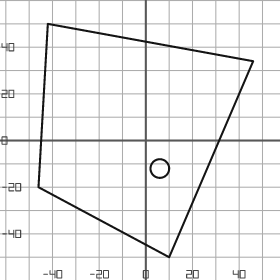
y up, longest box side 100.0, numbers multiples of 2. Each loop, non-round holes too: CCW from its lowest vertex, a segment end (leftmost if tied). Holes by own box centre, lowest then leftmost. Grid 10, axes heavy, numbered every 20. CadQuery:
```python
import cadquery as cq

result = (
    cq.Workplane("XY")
    .moveTo(10.0, -50.0)
    .lineTo(46.0, 34.0)
    .lineTo(-42.0, 50.0)
    .lineTo(-46.0, -20.0)
    .close()
    .moveTo(6.0, -12.0)
    .circle(4.0)
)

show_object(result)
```